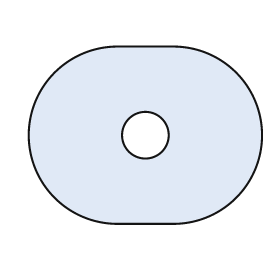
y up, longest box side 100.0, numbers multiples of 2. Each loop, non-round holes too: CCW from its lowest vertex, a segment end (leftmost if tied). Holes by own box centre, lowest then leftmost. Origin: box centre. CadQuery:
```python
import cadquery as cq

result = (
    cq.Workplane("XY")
    .moveTo(-12.0, -38.0)
    .lineTo(12.0, -38.0)
    .threePointArc((50.0, 0.0), (12.0, 38.0))
    .lineTo(-12.0, 38.0)
    .threePointArc((-50.0, 0.0), (-12.0, -38.0))
    .close()
    .moveTo(0.0, 0.0)
    .circle(10.0)
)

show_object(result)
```